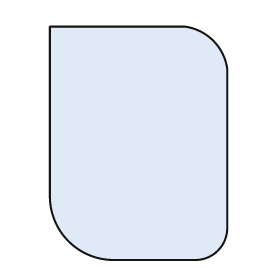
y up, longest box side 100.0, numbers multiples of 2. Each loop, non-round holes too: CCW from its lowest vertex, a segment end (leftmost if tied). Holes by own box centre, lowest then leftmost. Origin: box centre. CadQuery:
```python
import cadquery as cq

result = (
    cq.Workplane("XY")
    .moveTo(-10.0, -50.0)
    .lineTo(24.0, -50.0)
    .threePointArc((34.0, -46.0), (38.0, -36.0))
    .lineTo(38.0, 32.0)
    .threePointArc((32.0, 44.0), (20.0, 50.0))
    .lineTo(-38.0, 50.0)
    .lineTo(-38.0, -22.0)
    .threePointArc((-30.0, -42.0), (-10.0, -50.0))
    .close()
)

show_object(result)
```